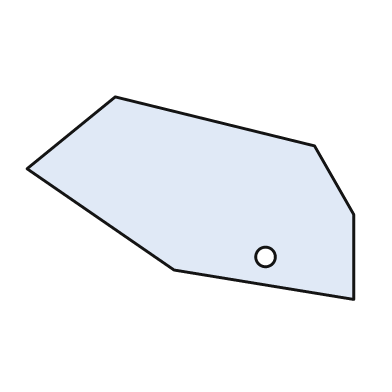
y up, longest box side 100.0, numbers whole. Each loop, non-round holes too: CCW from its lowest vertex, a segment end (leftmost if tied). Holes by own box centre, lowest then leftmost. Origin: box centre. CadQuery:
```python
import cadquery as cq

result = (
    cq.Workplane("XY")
    .moveTo(50.0, -31.0)
    .lineTo(50.0, -5.0)
    .lineTo(38.0, 16.0)
    .lineTo(-23.0, 31.0)
    .lineTo(-50.0, 9.0)
    .lineTo(-5.0, -22.0)
    .close()
    .moveTo(23.0, -18.0)
    .circle(3.0)
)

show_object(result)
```